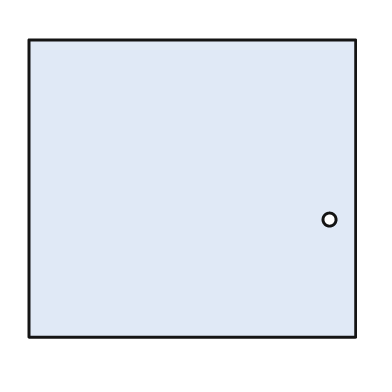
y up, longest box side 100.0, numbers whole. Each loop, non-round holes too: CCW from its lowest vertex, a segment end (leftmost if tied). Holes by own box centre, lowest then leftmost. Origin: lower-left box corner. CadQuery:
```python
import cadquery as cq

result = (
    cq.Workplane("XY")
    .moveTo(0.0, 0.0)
    .lineTo(100.0, 0.0)
    .lineTo(100.0, 91.0)
    .lineTo(0.0, 91.0)
    .close()
    .moveTo(92.0, 36.0)
    .circle(2.0)
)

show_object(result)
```